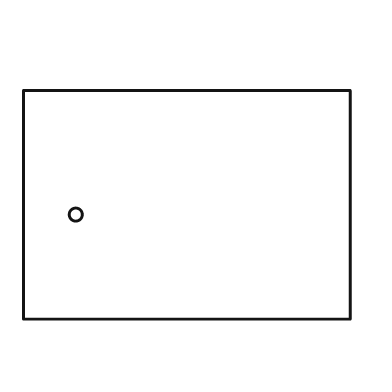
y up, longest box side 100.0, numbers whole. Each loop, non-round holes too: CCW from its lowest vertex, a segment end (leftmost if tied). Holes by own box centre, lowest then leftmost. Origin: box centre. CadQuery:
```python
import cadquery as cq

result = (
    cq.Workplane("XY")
    .moveTo(-50.0, -35.0)
    .lineTo(50.0, -35.0)
    .lineTo(50.0, 35.0)
    .lineTo(-50.0, 35.0)
    .close()
    .moveTo(-34.0, -3.0)
    .circle(2.0)
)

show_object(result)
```